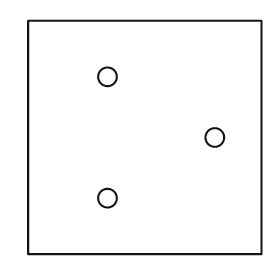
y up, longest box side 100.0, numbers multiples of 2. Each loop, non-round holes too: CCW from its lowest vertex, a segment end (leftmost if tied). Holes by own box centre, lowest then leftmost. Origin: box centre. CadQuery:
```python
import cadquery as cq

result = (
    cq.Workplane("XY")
    .moveTo(-50.0, -50.0)
    .lineTo(50.0, -50.0)
    .lineTo(50.0, 50.0)
    .lineTo(-50.0, 50.0)
    .close()
    .moveTo(-16.0, -26.0)
    .circle(4.0)
    .moveTo(30.0, 0.0)
    .circle(4.0)
    .moveTo(-16.0, 26.0)
    .circle(4.0)
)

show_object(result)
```